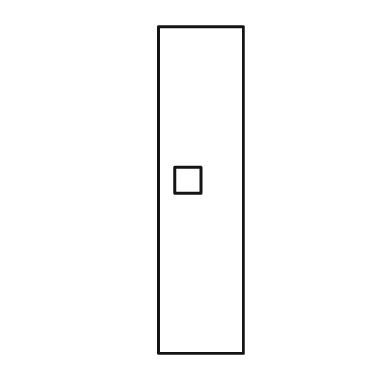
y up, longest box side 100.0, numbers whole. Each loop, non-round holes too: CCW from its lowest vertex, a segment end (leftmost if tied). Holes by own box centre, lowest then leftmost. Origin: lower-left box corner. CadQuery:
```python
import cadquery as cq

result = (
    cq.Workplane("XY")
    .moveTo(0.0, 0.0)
    .lineTo(26.0, 0.0)
    .lineTo(26.0, 100.0)
    .lineTo(0.0, 100.0)
    .close()
    .moveTo(5.0, 49.0)
    .lineTo(13.0, 49.0)
    .lineTo(13.0, 57.0)
    .lineTo(5.0, 57.0)
    .close()
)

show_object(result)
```